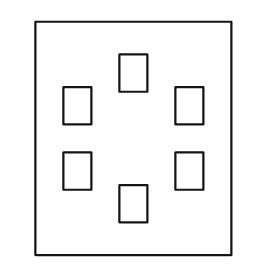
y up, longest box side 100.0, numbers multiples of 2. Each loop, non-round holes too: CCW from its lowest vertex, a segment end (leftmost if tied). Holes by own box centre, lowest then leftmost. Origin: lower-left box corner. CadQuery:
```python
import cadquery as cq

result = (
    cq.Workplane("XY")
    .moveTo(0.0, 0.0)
    .lineTo(84.0, 0.0)
    .lineTo(84.0, 100.0)
    .lineTo(0.0, 100.0)
    .close()
    .moveTo(36.0, 14.0)
    .lineTo(48.0, 14.0)
    .lineTo(48.0, 30.0)
    .lineTo(36.0, 30.0)
    .close()
    .moveTo(12.0, 28.0)
    .lineTo(24.0, 28.0)
    .lineTo(24.0, 44.0)
    .lineTo(12.0, 44.0)
    .close()
    .moveTo(60.0, 28.0)
    .lineTo(72.0, 28.0)
    .lineTo(72.0, 44.0)
    .lineTo(60.0, 44.0)
    .close()
    .moveTo(12.0, 56.0)
    .lineTo(24.0, 56.0)
    .lineTo(24.0, 72.0)
    .lineTo(12.0, 72.0)
    .close()
    .moveTo(60.0, 56.0)
    .lineTo(72.0, 56.0)
    .lineTo(72.0, 72.0)
    .lineTo(60.0, 72.0)
    .close()
    .moveTo(36.0, 70.0)
    .lineTo(48.0, 70.0)
    .lineTo(48.0, 86.0)
    .lineTo(36.0, 86.0)
    .close()
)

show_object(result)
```